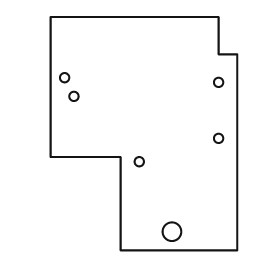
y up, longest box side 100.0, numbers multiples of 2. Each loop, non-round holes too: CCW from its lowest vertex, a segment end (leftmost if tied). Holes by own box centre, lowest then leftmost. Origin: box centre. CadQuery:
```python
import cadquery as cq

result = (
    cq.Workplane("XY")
    .moveTo(-10.0, -50.0)
    .lineTo(40.0, -50.0)
    .lineTo(40.0, 34.0)
    .lineTo(32.0, 34.0)
    .lineTo(32.0, 50.0)
    .lineTo(-40.0, 50.0)
    .lineTo(-40.0, -10.0)
    .lineTo(-10.0, -10.0)
    .close()
    .moveTo(12.0, -42.0)
    .circle(4.0)
    .moveTo(-2.0, -12.0)
    .circle(2.0)
    .moveTo(32.0, -2.0)
    .circle(2.0)
    .moveTo(-30.0, 16.0)
    .circle(2.0)
    .moveTo(32.0, 22.0)
    .circle(2.0)
    .moveTo(-34.0, 24.0)
    .circle(2.0)
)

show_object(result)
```